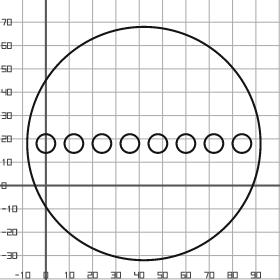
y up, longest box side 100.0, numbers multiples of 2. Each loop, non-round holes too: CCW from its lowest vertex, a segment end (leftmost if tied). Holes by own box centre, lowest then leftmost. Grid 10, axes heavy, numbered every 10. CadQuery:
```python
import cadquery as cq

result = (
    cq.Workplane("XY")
    .moveTo(42.0, 18.0)
    .circle(50.0)
    .moveTo(0.0, 18.0)
    .circle(4.0)
    .moveTo(12.0, 18.0)
    .circle(4.0)
    .moveTo(24.0, 18.0)
    .circle(4.0)
    .moveTo(36.0, 18.0)
    .circle(4.0)
    .moveTo(48.0, 18.0)
    .circle(4.0)
    .moveTo(60.0, 18.0)
    .circle(4.0)
    .moveTo(72.0, 18.0)
    .circle(4.0)
    .moveTo(84.0, 18.0)
    .circle(4.0)
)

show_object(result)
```